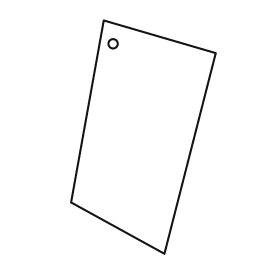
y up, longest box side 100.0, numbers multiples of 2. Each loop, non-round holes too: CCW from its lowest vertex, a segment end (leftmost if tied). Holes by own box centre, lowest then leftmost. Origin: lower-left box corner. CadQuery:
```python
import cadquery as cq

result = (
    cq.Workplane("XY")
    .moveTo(40.0, 0.0)
    .lineTo(62.0, 86.0)
    .lineTo(14.0, 100.0)
    .lineTo(0.0, 22.0)
    .close()
    .moveTo(18.0, 90.0)
    .circle(2.0)
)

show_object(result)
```